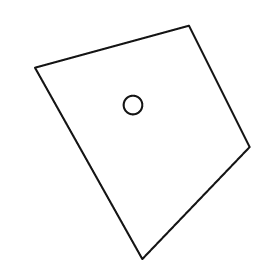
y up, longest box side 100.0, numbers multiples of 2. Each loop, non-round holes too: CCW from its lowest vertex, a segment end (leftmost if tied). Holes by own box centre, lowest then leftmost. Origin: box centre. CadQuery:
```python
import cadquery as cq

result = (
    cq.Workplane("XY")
    .moveTo(0.0, -50.0)
    .lineTo(46.0, -2.0)
    .lineTo(20.0, 50.0)
    .lineTo(-46.0, 32.0)
    .close()
    .moveTo(-4.0, 16.0)
    .circle(4.0)
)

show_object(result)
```